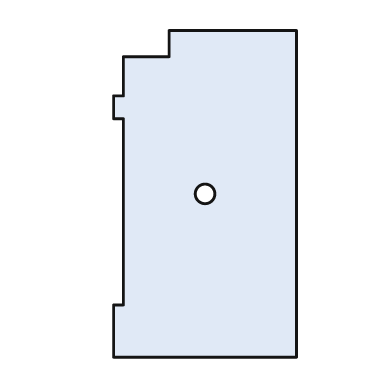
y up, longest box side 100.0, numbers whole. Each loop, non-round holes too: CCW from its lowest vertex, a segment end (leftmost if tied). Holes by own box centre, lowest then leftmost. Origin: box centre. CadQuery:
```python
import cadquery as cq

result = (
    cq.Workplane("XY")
    .moveTo(-28.0, -50.0)
    .lineTo(28.0, -50.0)
    .lineTo(28.0, 50.0)
    .lineTo(-11.0, 50.0)
    .lineTo(-11.0, 42.0)
    .lineTo(-25.0, 42.0)
    .lineTo(-25.0, 30.0)
    .lineTo(-28.0, 30.0)
    .lineTo(-28.0, 23.0)
    .lineTo(-25.0, 23.0)
    .lineTo(-25.0, -34.0)
    .lineTo(-28.0, -34.0)
    .close()
    .moveTo(0.0, 0.0)
    .circle(3.0)
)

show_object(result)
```